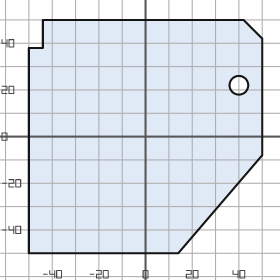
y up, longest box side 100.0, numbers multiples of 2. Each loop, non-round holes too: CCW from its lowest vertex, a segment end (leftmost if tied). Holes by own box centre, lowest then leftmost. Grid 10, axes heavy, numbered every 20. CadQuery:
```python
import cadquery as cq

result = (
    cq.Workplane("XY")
    .moveTo(-50.0, -50.0)
    .lineTo(14.0, -50.0)
    .lineTo(50.0, -8.0)
    .lineTo(50.0, 42.0)
    .lineTo(42.0, 50.0)
    .lineTo(-44.0, 50.0)
    .lineTo(-44.0, 38.0)
    .lineTo(-50.0, 38.0)
    .close()
    .moveTo(40.0, 22.0)
    .circle(4.0)
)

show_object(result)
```